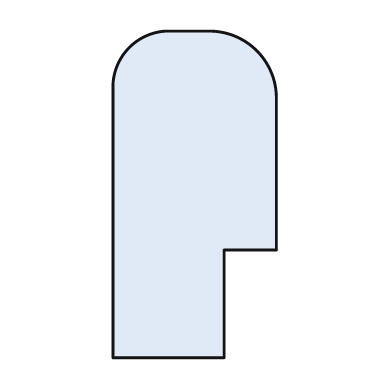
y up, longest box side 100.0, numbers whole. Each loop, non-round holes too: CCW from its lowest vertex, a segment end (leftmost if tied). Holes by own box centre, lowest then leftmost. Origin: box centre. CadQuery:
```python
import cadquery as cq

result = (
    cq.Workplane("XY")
    .moveTo(-25.0, -50.0)
    .lineTo(9.0, -50.0)
    .lineTo(9.0, -17.0)
    .lineTo(25.0, -17.0)
    .lineTo(25.0, 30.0)
    .threePointArc((19.0, 44.0), (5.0, 50.0))
    .lineTo(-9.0, 50.0)
    .threePointArc((-20.0, 45.0), (-25.0, 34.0))
    .close()
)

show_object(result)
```